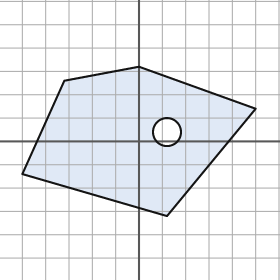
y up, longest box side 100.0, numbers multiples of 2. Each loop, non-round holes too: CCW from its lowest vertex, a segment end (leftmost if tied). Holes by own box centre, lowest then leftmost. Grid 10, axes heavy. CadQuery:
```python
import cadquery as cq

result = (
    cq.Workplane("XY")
    .moveTo(12.0, -32.0)
    .lineTo(50.0, 14.0)
    .lineTo(0.0, 32.0)
    .lineTo(-32.0, 26.0)
    .lineTo(-50.0, -14.0)
    .close()
    .moveTo(12.0, 4.0)
    .circle(6.0)
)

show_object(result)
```